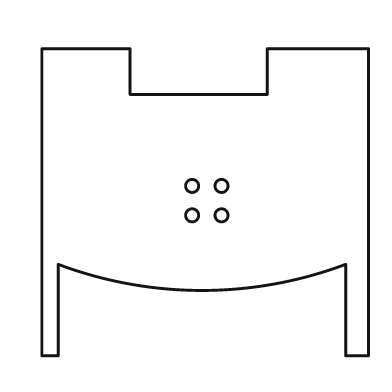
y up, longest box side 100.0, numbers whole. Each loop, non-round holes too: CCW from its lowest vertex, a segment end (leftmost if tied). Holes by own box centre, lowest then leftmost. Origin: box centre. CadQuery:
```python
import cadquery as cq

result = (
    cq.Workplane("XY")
    .moveTo(-50.0, -47.0)
    .lineTo(-45.0, -47.0)
    .lineTo(-45.0, -19.0)
    .threePointArc((-1.0, -27.0), (43.0, -19.0))
    .lineTo(43.0, -47.0)
    .lineTo(50.0, -47.0)
    .lineTo(50.0, 47.0)
    .lineTo(19.0, 47.0)
    .lineTo(19.0, 33.0)
    .lineTo(-23.0, 33.0)
    .lineTo(-23.0, 47.0)
    .lineTo(-50.0, 47.0)
    .close()
    .moveTo(-4.0, -4.0)
    .circle(2.0)
    .moveTo(5.0, -4.0)
    .circle(2.0)
    .moveTo(-4.0, 5.0)
    .circle(2.0)
    .moveTo(5.0, 5.0)
    .circle(2.0)
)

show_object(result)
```